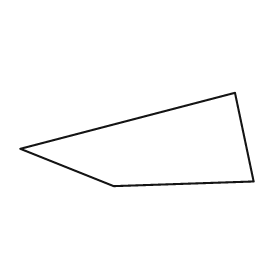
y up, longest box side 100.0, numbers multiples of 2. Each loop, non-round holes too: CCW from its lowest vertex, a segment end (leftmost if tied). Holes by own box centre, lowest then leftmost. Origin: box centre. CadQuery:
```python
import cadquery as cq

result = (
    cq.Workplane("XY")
    .moveTo(-10.0, -20.0)
    .lineTo(50.0, -18.0)
    .lineTo(42.0, 20.0)
    .lineTo(-50.0, -4.0)
    .close()
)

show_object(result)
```